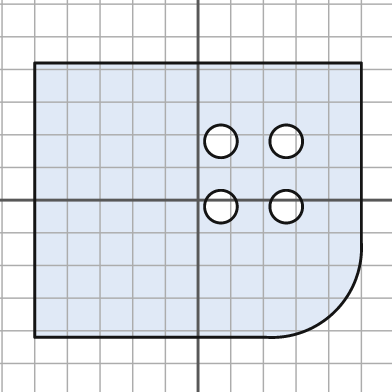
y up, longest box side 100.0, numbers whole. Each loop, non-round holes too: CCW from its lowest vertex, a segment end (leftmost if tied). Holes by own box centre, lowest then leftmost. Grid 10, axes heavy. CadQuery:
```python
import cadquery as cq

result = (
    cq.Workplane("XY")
    .moveTo(-50.0, -42.0)
    .lineTo(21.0, -42.0)
    .threePointArc((42.0, -34.0), (50.0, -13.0))
    .lineTo(50.0, 42.0)
    .lineTo(-50.0, 42.0)
    .close()
    .moveTo(7.0, -2.0)
    .circle(5.0)
    .moveTo(27.0, -2.0)
    .circle(5.0)
    .moveTo(7.0, 18.0)
    .circle(5.0)
    .moveTo(27.0, 18.0)
    .circle(5.0)
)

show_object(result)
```